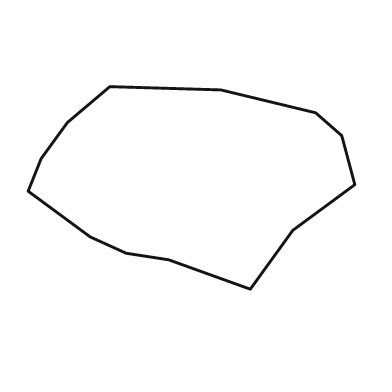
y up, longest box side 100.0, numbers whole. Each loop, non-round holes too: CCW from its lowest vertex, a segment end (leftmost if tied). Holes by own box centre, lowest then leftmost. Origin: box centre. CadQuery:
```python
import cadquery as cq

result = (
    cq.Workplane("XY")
    .moveTo(18.0, -31.0)
    .lineTo(31.0, -13.0)
    .lineTo(50.0, 1.0)
    .lineTo(46.0, 16.0)
    .lineTo(38.0, 23.0)
    .lineTo(9.0, 30.0)
    .lineTo(-25.0, 31.0)
    .lineTo(-38.0, 20.0)
    .lineTo(-46.0, 9.0)
    .lineTo(-50.0, -1.0)
    .lineTo(-31.0, -15.0)
    .lineTo(-20.0, -20.0)
    .lineTo(-7.0, -22.0)
    .close()
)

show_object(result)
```